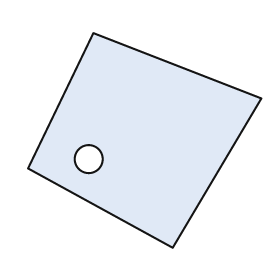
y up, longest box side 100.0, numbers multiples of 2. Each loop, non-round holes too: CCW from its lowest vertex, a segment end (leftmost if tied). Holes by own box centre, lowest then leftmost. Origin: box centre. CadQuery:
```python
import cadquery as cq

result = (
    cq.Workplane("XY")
    .moveTo(12.0, -46.0)
    .lineTo(50.0, 18.0)
    .lineTo(-22.0, 46.0)
    .lineTo(-50.0, -12.0)
    .close()
    .moveTo(-24.0, -8.0)
    .circle(6.0)
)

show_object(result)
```